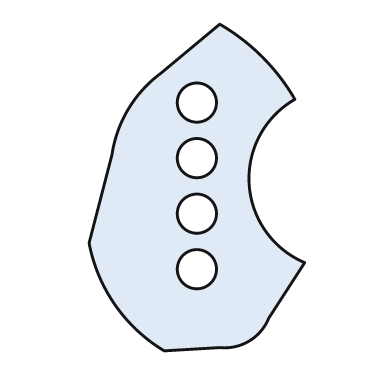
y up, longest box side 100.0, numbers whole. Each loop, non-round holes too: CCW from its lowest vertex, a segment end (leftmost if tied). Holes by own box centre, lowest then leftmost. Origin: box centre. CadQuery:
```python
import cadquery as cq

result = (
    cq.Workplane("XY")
    .moveTo(-10.0, -50.0)
    .lineTo(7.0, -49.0)
    .threePointArc((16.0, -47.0), (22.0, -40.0))
    .lineTo(33.0, -23.0)
    .threePointArc((16.0, 1.0), (30.0, 27.0))
    .threePointArc((20.0, 40.0), (7.0, 50.0))
    .lineTo(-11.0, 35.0)
    .threePointArc((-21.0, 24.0), (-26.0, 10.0))
    .lineTo(-33.0, -17.0)
    .threePointArc((-25.0, -36.0), (-10.0, -50.0))
    .close()
    .moveTo(0.0, -25.0)
    .circle(6.0)
    .moveTo(0.0, -8.0)
    .circle(6.0)
    .moveTo(0.0, 9.0)
    .circle(6.0)
    .moveTo(0.0, 26.0)
    .circle(6.0)
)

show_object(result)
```